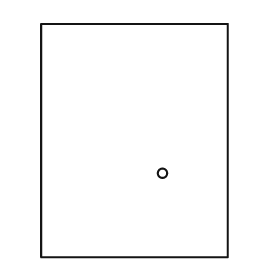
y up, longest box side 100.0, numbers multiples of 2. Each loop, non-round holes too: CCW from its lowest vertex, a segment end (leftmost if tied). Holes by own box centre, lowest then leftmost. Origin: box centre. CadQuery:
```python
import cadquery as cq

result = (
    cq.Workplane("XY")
    .moveTo(-40.0, -50.0)
    .lineTo(40.0, -50.0)
    .lineTo(40.0, 50.0)
    .lineTo(-40.0, 50.0)
    .close()
    .moveTo(12.0, -14.0)
    .circle(2.0)
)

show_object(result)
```